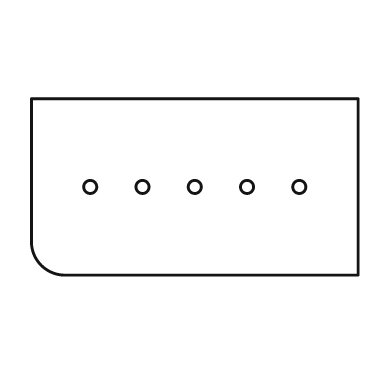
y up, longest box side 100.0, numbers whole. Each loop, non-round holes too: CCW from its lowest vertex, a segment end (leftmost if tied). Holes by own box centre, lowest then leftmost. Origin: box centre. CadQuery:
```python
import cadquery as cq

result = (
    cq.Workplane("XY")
    .moveTo(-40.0, -27.0)
    .lineTo(50.0, -27.0)
    .lineTo(50.0, 27.0)
    .lineTo(-50.0, 27.0)
    .lineTo(-50.0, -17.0)
    .threePointArc((-47.0, -24.0), (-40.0, -27.0))
    .close()
    .moveTo(-32.0, 0.0)
    .circle(2.0)
    .moveTo(-16.0, 0.0)
    .circle(2.0)
    .moveTo(0.0, 0.0)
    .circle(2.0)
    .moveTo(16.0, 0.0)
    .circle(2.0)
    .moveTo(32.0, 0.0)
    .circle(2.0)
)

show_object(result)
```